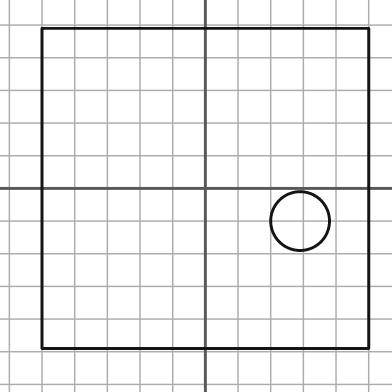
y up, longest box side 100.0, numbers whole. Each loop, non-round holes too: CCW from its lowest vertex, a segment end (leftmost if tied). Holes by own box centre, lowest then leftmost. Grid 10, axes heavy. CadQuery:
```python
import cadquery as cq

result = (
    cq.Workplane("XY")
    .moveTo(-50.0, -49.0)
    .lineTo(50.0, -49.0)
    .lineTo(50.0, 49.0)
    .lineTo(-50.0, 49.0)
    .close()
    .moveTo(29.0, -10.0)
    .circle(9.0)
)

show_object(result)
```